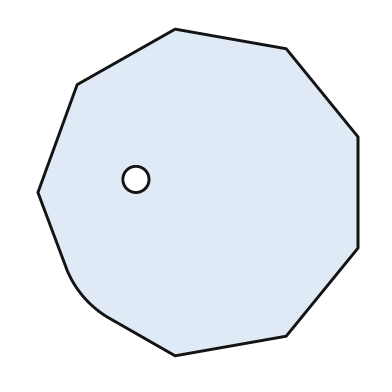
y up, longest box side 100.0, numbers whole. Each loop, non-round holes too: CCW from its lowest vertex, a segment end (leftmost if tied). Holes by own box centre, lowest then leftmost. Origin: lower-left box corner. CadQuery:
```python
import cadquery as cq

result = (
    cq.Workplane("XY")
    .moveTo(42.0, 0.0)
    .lineTo(76.0, 6.0)
    .lineTo(98.0, 33.0)
    .lineTo(98.0, 67.0)
    .lineTo(76.0, 94.0)
    .lineTo(42.0, 100.0)
    .lineTo(12.0, 83.0)
    .lineTo(0.0, 50.0)
    .lineTo(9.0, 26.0)
    .threePointArc((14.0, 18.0), (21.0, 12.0))
    .close()
    .moveTo(30.0, 54.0)
    .circle(4.0)
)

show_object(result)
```